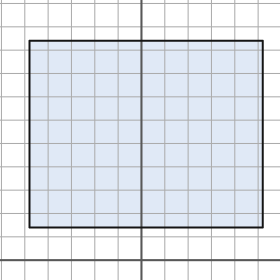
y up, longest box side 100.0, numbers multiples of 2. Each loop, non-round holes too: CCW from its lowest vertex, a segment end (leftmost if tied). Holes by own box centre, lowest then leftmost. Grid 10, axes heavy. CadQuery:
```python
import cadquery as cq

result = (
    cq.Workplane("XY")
    .moveTo(-48.0, 14.0)
    .lineTo(52.0, 14.0)
    .lineTo(52.0, 94.0)
    .lineTo(-48.0, 94.0)
    .close()
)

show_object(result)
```